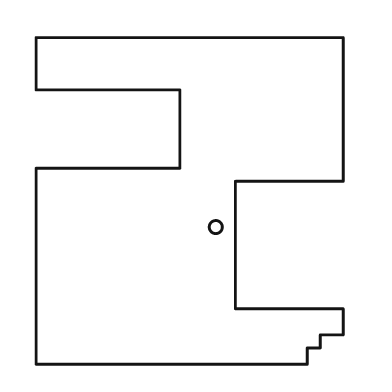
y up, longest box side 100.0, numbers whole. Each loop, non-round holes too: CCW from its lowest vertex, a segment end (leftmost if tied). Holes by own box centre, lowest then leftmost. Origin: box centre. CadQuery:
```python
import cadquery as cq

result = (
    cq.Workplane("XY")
    .moveTo(-47.0, -50.0)
    .lineTo(36.0, -50.0)
    .lineTo(36.0, -45.0)
    .lineTo(40.0, -45.0)
    .lineTo(40.0, -41.0)
    .lineTo(47.0, -41.0)
    .lineTo(47.0, -33.0)
    .lineTo(14.0, -33.0)
    .lineTo(14.0, 6.0)
    .lineTo(47.0, 6.0)
    .lineTo(47.0, 50.0)
    .lineTo(-47.0, 50.0)
    .lineTo(-47.0, 34.0)
    .lineTo(-3.0, 34.0)
    .lineTo(-3.0, 10.0)
    .lineTo(-47.0, 10.0)
    .close()
    .moveTo(8.0, -8.0)
    .circle(2.0)
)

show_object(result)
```